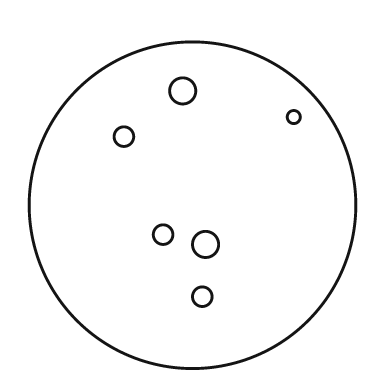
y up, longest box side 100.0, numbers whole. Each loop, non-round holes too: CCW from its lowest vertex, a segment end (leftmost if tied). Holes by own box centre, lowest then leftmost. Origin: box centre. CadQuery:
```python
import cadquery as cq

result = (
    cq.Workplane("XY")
    .moveTo(0.0, 0.0)
    .circle(50.0)
    .moveTo(3.0, -28.0)
    .circle(3.0)
    .moveTo(4.0, -12.0)
    .circle(4.0)
    .moveTo(-9.0, -9.0)
    .circle(3.0)
    .moveTo(-21.0, 21.0)
    .circle(3.0)
    .moveTo(31.0, 27.0)
    .circle(2.0)
    .moveTo(-3.0, 35.0)
    .circle(4.0)
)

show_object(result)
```